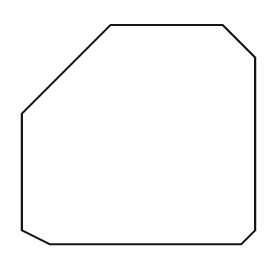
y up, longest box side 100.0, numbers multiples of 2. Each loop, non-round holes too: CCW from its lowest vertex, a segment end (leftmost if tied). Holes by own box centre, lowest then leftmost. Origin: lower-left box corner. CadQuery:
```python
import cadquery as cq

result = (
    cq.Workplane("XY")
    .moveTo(12.0, 0.0)
    .lineTo(94.0, 0.0)
    .lineTo(100.0, 6.0)
    .lineTo(100.0, 80.0)
    .lineTo(86.0, 94.0)
    .lineTo(38.0, 94.0)
    .lineTo(0.0, 56.0)
    .lineTo(0.0, 6.0)
    .close()
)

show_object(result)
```